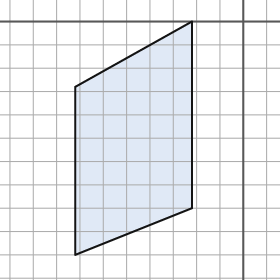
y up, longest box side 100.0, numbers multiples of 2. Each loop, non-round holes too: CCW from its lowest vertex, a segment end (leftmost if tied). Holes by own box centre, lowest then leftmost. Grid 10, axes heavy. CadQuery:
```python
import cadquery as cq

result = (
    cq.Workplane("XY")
    .moveTo(-72.0, -100.0)
    .lineTo(-22.0, -80.0)
    .lineTo(-22.0, 0.0)
    .lineTo(-72.0, -28.0)
    .close()
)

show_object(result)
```